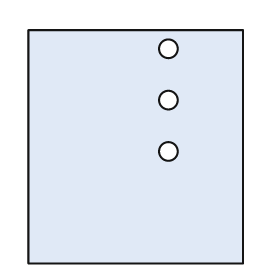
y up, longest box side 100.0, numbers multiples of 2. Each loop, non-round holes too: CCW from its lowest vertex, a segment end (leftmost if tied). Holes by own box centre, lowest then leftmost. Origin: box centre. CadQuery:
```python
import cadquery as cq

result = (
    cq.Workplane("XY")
    .moveTo(-46.0, -50.0)
    .lineTo(46.0, -50.0)
    .lineTo(46.0, 50.0)
    .lineTo(-46.0, 50.0)
    .close()
    .moveTo(14.0, -2.0)
    .circle(4.0)
    .moveTo(14.0, 20.0)
    .circle(4.0)
    .moveTo(14.0, 42.0)
    .circle(4.0)
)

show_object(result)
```